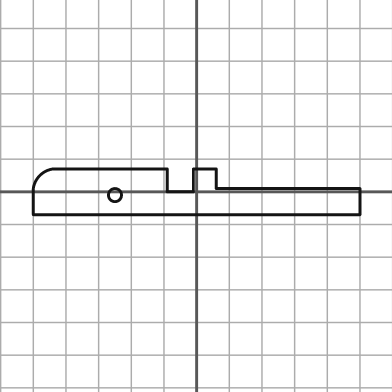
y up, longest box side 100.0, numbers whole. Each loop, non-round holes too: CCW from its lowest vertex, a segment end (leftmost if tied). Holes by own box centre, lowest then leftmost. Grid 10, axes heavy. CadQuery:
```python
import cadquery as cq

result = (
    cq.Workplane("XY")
    .moveTo(-50.0, -7.0)
    .lineTo(50.0, -7.0)
    .lineTo(50.0, 1.0)
    .lineTo(6.0, 1.0)
    .lineTo(6.0, 7.0)
    .lineTo(-1.0, 7.0)
    .lineTo(-1.0, 0.0)
    .lineTo(-9.0, 0.0)
    .lineTo(-9.0, 7.0)
    .lineTo(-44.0, 7.0)
    .threePointArc((-48.0, 5.0), (-50.0, 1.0))
    .close()
    .moveTo(-25.0, -1.0)
    .circle(2.0)
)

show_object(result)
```